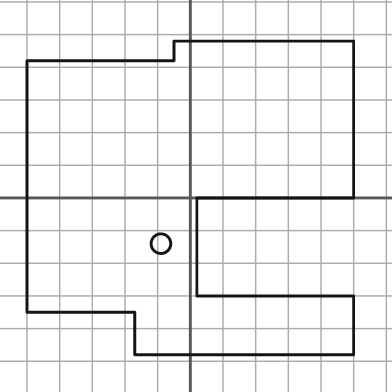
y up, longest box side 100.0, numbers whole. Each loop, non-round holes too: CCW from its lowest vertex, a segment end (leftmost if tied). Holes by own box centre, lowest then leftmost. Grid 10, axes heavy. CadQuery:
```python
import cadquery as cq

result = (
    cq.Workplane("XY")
    .moveTo(-17.0, -48.0)
    .lineTo(50.0, -48.0)
    .lineTo(50.0, -30.0)
    .lineTo(2.0, -30.0)
    .lineTo(2.0, 0.0)
    .lineTo(50.0, 0.0)
    .lineTo(50.0, 48.0)
    .lineTo(-5.0, 48.0)
    .lineTo(-5.0, 42.0)
    .lineTo(-50.0, 42.0)
    .lineTo(-50.0, -35.0)
    .lineTo(-17.0, -35.0)
    .close()
    .moveTo(-9.0, -14.0)
    .circle(3.0)
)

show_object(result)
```